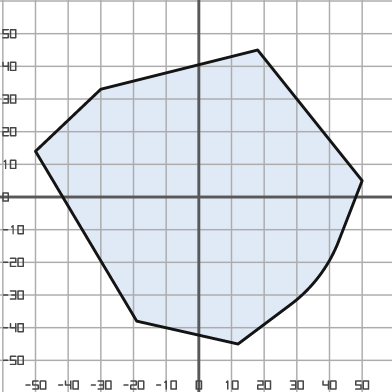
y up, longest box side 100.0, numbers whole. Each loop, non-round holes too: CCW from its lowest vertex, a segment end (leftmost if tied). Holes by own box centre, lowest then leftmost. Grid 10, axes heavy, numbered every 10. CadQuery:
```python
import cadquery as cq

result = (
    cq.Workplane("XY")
    .moveTo(12.0, -45.0)
    .lineTo(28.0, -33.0)
    .threePointArc((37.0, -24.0), (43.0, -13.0))
    .lineTo(50.0, 5.0)
    .lineTo(18.0, 45.0)
    .lineTo(-30.0, 33.0)
    .lineTo(-50.0, 14.0)
    .lineTo(-19.0, -38.0)
    .close()
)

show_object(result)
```